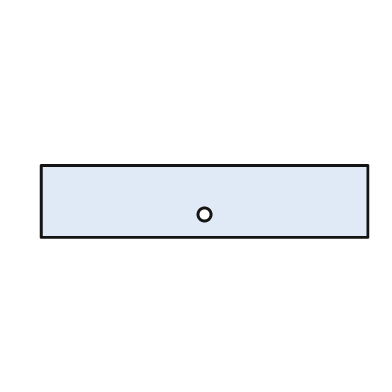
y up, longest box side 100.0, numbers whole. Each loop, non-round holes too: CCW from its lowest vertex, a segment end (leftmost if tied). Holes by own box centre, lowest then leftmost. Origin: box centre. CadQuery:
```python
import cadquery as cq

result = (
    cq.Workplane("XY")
    .moveTo(-50.0, -11.0)
    .lineTo(50.0, -11.0)
    .lineTo(50.0, 11.0)
    .lineTo(-50.0, 11.0)
    .close()
    .moveTo(0.0, -4.0)
    .circle(2.0)
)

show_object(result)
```